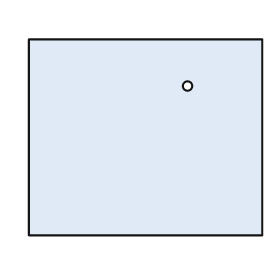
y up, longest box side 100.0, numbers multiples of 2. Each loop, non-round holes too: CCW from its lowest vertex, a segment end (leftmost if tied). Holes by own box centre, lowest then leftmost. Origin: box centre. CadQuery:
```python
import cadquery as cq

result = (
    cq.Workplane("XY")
    .moveTo(-50.0, -42.0)
    .lineTo(50.0, -42.0)
    .lineTo(50.0, 42.0)
    .lineTo(-50.0, 42.0)
    .close()
    .moveTo(18.0, 22.0)
    .circle(2.0)
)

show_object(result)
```